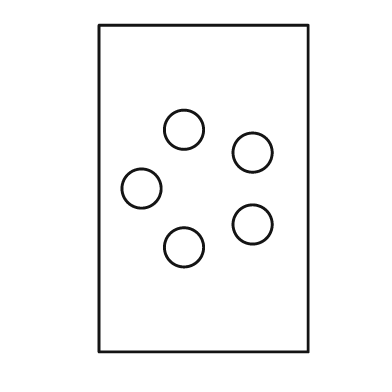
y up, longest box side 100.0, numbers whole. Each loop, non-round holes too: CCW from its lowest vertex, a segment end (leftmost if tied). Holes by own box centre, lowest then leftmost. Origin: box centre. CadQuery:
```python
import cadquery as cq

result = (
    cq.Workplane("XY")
    .moveTo(-32.0, -50.0)
    .lineTo(32.0, -50.0)
    .lineTo(32.0, 50.0)
    .lineTo(-32.0, 50.0)
    .close()
    .moveTo(-6.0, -18.0)
    .circle(6.0)
    .moveTo(15.0, -11.0)
    .circle(6.0)
    .moveTo(-19.0, 0.0)
    .circle(6.0)
    .moveTo(15.0, 11.0)
    .circle(6.0)
    .moveTo(-6.0, 18.0)
    .circle(6.0)
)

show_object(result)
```